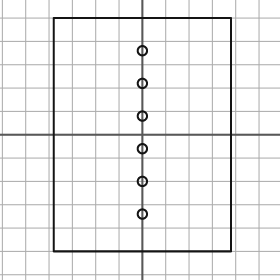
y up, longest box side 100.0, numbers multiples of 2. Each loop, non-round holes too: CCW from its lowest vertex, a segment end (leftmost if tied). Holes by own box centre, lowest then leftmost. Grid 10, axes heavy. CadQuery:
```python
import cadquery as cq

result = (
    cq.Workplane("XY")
    .moveTo(-38.0, -50.0)
    .lineTo(38.0, -50.0)
    .lineTo(38.0, 50.0)
    .lineTo(-38.0, 50.0)
    .close()
    .moveTo(0.0, -34.0)
    .circle(2.0)
    .moveTo(0.0, -20.0)
    .circle(2.0)
    .moveTo(0.0, -6.0)
    .circle(2.0)
    .moveTo(0.0, 8.0)
    .circle(2.0)
    .moveTo(0.0, 22.0)
    .circle(2.0)
    .moveTo(0.0, 36.0)
    .circle(2.0)
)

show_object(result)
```